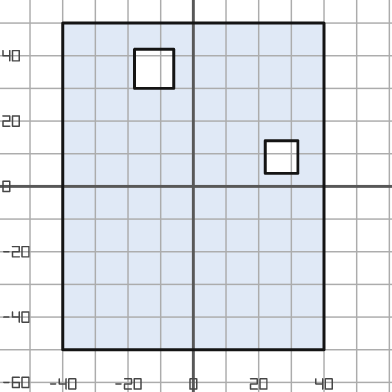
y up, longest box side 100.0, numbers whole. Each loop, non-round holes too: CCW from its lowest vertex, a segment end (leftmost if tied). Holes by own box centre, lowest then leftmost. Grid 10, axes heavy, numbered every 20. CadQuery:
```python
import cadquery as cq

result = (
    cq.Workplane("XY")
    .moveTo(-40.0, -50.0)
    .lineTo(40.0, -50.0)
    .lineTo(40.0, 50.0)
    .lineTo(-40.0, 50.0)
    .close()
    .moveTo(22.0, 4.0)
    .lineTo(32.0, 4.0)
    .lineTo(32.0, 14.0)
    .lineTo(22.0, 14.0)
    .close()
    .moveTo(-18.0, 30.0)
    .lineTo(-6.0, 30.0)
    .lineTo(-6.0, 42.0)
    .lineTo(-18.0, 42.0)
    .close()
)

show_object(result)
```